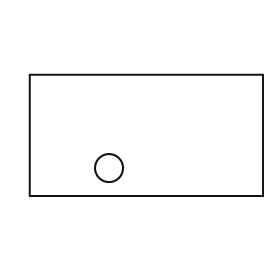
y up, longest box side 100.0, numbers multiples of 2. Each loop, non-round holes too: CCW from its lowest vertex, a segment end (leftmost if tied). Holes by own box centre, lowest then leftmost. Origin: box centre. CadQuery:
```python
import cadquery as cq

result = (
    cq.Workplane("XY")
    .moveTo(-50.0, -26.0)
    .lineTo(50.0, -26.0)
    .lineTo(50.0, 26.0)
    .lineTo(-50.0, 26.0)
    .close()
    .moveTo(-16.0, -14.0)
    .circle(6.0)
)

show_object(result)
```